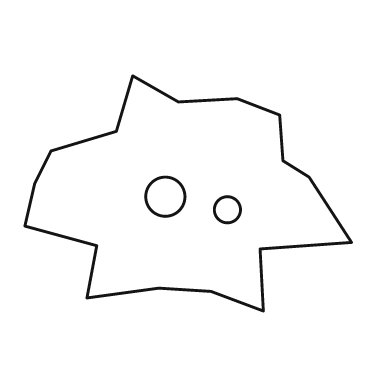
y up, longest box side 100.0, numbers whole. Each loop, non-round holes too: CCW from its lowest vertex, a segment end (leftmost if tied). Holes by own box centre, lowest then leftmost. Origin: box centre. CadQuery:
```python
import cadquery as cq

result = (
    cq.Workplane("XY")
    .moveTo(23.0, -36.0)
    .lineTo(22.0, -17.0)
    .lineTo(50.0, -15.0)
    .lineTo(37.0, 5.0)
    .lineTo(29.0, 10.0)
    .lineTo(28.0, 24.0)
    .lineTo(15.0, 29.0)
    .lineTo(-3.0, 28.0)
    .lineTo(-17.0, 36.0)
    .lineTo(-22.0, 19.0)
    .lineTo(-42.0, 13.0)
    .lineTo(-47.0, 3.0)
    .lineTo(-50.0, -10.0)
    .lineTo(-28.0, -16.0)
    .lineTo(-31.0, -32.0)
    .lineTo(-9.0, -29.0)
    .lineTo(7.0, -30.0)
    .close()
    .moveTo(12.0, -5.0)
    .circle(4.0)
    .moveTo(-7.0, -1.0)
    .circle(6.0)
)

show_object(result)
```